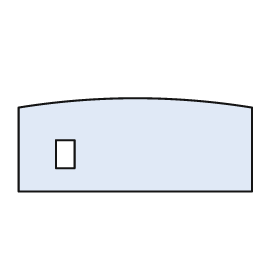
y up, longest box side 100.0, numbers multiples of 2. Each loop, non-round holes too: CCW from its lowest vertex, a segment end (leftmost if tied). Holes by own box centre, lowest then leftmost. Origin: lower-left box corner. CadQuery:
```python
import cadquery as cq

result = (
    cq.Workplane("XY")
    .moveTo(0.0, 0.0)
    .lineTo(100.0, 0.0)
    .lineTo(100.0, 36.0)
    .threePointArc((50.0, 40.0), (0.0, 36.0))
    .close()
    .moveTo(16.0, 10.0)
    .lineTo(24.0, 10.0)
    .lineTo(24.0, 22.0)
    .lineTo(16.0, 22.0)
    .close()
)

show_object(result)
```